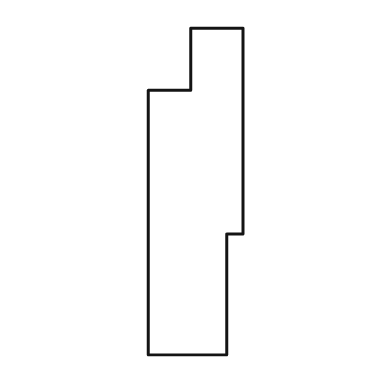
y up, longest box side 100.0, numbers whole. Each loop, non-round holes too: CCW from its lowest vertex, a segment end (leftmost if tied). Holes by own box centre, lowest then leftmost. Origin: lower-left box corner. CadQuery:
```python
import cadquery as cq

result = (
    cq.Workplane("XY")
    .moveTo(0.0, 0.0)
    .lineTo(24.0, 0.0)
    .lineTo(24.0, 37.0)
    .lineTo(29.0, 37.0)
    .lineTo(29.0, 100.0)
    .lineTo(13.0, 100.0)
    .lineTo(13.0, 81.0)
    .lineTo(0.0, 81.0)
    .close()
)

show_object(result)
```